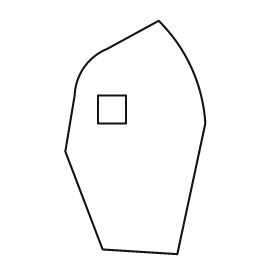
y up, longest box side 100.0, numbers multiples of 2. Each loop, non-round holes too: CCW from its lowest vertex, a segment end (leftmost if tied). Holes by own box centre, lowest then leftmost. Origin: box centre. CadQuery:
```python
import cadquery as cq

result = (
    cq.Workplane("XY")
    .moveTo(18.0, -50.0)
    .lineTo(30.0, 6.0)
    .threePointArc((24.0, 30.0), (10.0, 50.0))
    .lineTo(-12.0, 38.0)
    .threePointArc((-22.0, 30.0), (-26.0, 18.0))
    .lineTo(-30.0, -6.0)
    .lineTo(-14.0, -48.0)
    .close()
    .moveTo(-16.0, 6.0)
    .lineTo(-4.0, 6.0)
    .lineTo(-4.0, 18.0)
    .lineTo(-16.0, 18.0)
    .close()
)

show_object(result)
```